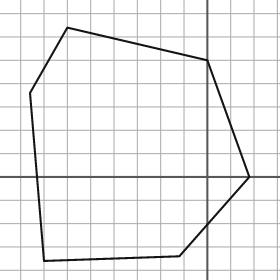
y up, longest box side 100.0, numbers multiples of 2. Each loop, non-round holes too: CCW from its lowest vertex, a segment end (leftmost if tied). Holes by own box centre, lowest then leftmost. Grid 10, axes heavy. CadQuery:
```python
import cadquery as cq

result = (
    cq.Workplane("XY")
    .moveTo(-70.0, -36.0)
    .lineTo(-12.0, -34.0)
    .lineTo(18.0, 0.0)
    .lineTo(0.0, 50.0)
    .lineTo(-60.0, 64.0)
    .lineTo(-76.0, 36.0)
    .close()
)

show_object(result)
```